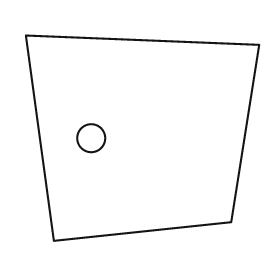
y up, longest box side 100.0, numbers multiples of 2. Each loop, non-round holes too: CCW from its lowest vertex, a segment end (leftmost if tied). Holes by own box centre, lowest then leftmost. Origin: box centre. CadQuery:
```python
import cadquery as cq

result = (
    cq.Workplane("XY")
    .moveTo(-38.0, -44.0)
    .lineTo(38.0, -36.0)
    .lineTo(50.0, 40.0)
    .lineTo(-50.0, 44.0)
    .close()
    .moveTo(-22.0, 0.0)
    .circle(6.0)
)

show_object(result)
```